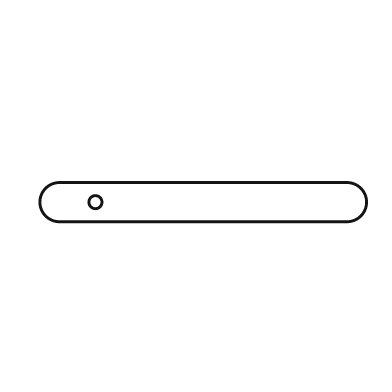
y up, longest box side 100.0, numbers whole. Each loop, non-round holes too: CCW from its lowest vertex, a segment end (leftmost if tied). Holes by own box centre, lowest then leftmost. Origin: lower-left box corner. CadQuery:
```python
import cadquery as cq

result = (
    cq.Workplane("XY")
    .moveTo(6.0, 0.0)
    .lineTo(94.0, 0.0)
    .threePointArc((100.0, 6.0), (94.0, 12.0))
    .lineTo(6.0, 12.0)
    .threePointArc((0.0, 6.0), (6.0, 0.0))
    .close()
    .moveTo(17.0, 6.0)
    .circle(2.0)
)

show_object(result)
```